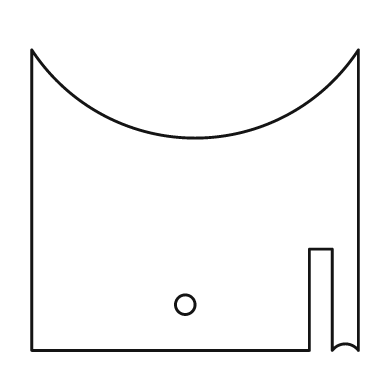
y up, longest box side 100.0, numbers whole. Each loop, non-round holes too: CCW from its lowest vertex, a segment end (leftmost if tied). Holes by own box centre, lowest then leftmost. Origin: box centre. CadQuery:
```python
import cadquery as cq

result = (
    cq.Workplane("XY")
    .moveTo(-50.0, -46.0)
    .lineTo(35.0, -46.0)
    .lineTo(35.0, -15.0)
    .lineTo(42.0, -15.0)
    .lineTo(42.0, -46.0)
    .threePointArc((46.0, -44.0), (50.0, -46.0))
    .lineTo(50.0, 46.0)
    .threePointArc((0.0, 19.0), (-50.0, 46.0))
    .close()
    .moveTo(-3.0, -32.0)
    .circle(3.0)
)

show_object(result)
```